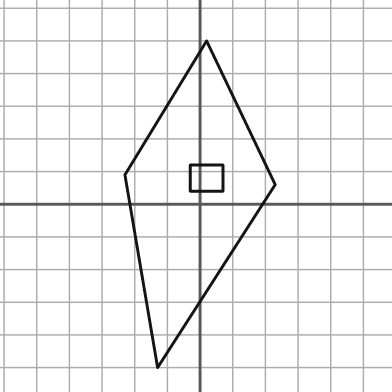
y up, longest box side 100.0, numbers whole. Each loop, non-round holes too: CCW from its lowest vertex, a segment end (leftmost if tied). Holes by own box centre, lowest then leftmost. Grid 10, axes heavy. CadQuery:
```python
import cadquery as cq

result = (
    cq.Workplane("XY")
    .moveTo(-13.0, -50.0)
    .lineTo(23.0, 6.0)
    .lineTo(2.0, 50.0)
    .lineTo(-23.0, 9.0)
    .close()
    .moveTo(-3.0, 4.0)
    .lineTo(7.0, 4.0)
    .lineTo(7.0, 12.0)
    .lineTo(-3.0, 12.0)
    .close()
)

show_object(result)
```